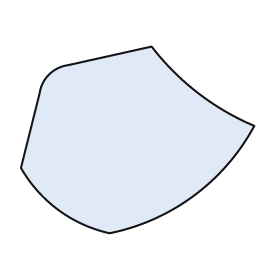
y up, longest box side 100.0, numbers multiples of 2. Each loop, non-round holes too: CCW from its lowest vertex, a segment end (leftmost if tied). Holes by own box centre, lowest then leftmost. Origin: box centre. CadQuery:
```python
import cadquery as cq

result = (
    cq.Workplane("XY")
    .moveTo(-12.0, -40.0)
    .threePointArc((24.0, -24.0), (50.0, 6.0))
    .threePointArc((26.0, 20.0), (6.0, 40.0))
    .lineTo(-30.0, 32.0)
    .threePointArc((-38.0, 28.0), (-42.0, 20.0))
    .lineTo(-50.0, -12.0)
    .threePointArc((-34.0, -30.0), (-12.0, -40.0))
    .close()
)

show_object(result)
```